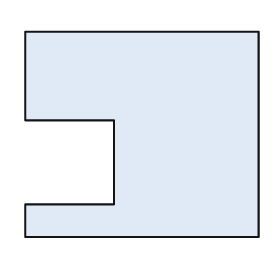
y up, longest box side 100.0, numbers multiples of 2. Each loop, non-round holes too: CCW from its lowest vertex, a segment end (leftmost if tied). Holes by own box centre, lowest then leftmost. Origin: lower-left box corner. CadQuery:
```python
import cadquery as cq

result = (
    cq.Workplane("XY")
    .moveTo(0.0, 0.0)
    .lineTo(100.0, 0.0)
    .lineTo(100.0, 88.0)
    .lineTo(0.0, 88.0)
    .lineTo(0.0, 50.0)
    .lineTo(38.0, 50.0)
    .lineTo(38.0, 14.0)
    .lineTo(0.0, 14.0)
    .close()
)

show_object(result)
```